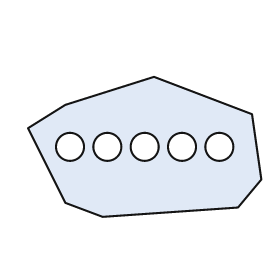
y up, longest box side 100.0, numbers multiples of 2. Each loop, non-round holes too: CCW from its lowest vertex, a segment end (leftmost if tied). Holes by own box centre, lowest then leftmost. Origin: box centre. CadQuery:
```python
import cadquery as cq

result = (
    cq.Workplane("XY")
    .moveTo(-18.0, -30.0)
    .lineTo(40.0, -26.0)
    .lineTo(50.0, -14.0)
    .lineTo(46.0, 14.0)
    .lineTo(4.0, 30.0)
    .lineTo(-34.0, 18.0)
    .lineTo(-50.0, 8.0)
    .lineTo(-34.0, -24.0)
    .close()
    .moveTo(-32.0, 0.0)
    .circle(6.0)
    .moveTo(-16.0, 0.0)
    .circle(6.0)
    .moveTo(0.0, 0.0)
    .circle(6.0)
    .moveTo(16.0, 0.0)
    .circle(6.0)
    .moveTo(32.0, 0.0)
    .circle(6.0)
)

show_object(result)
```